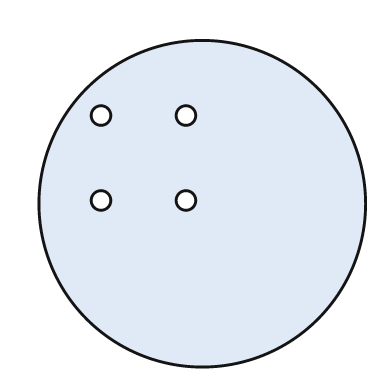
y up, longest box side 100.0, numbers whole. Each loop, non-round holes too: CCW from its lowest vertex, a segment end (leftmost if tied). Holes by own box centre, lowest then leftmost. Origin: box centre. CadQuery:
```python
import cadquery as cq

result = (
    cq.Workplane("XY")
    .moveTo(0.0, 0.0)
    .circle(50.0)
    .moveTo(-31.0, 1.0)
    .circle(3.0)
    .moveTo(-5.0, 1.0)
    .circle(3.0)
    .moveTo(-31.0, 27.0)
    .circle(3.0)
    .moveTo(-5.0, 27.0)
    .circle(3.0)
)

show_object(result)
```